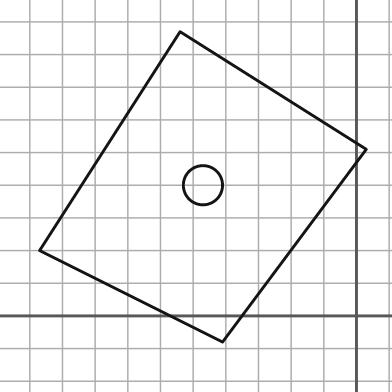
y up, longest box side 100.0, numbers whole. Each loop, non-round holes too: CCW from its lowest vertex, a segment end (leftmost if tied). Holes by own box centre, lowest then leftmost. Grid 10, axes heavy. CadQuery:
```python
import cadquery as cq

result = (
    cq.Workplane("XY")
    .moveTo(-41.0, -8.0)
    .lineTo(3.0, 51.0)
    .lineTo(-54.0, 87.0)
    .lineTo(-97.0, 20.0)
    .close()
    .moveTo(-47.0, 40.0)
    .circle(6.0)
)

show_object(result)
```